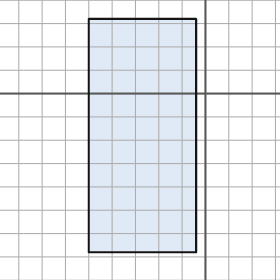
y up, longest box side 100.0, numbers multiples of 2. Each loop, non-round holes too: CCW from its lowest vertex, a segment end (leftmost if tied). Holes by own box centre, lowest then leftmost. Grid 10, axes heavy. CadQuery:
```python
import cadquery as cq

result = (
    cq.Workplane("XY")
    .moveTo(-50.0, -68.0)
    .lineTo(-4.0, -68.0)
    .lineTo(-4.0, 32.0)
    .lineTo(-50.0, 32.0)
    .close()
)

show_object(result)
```